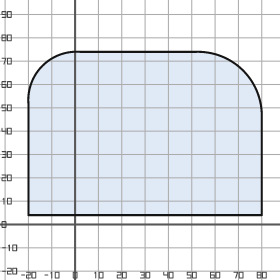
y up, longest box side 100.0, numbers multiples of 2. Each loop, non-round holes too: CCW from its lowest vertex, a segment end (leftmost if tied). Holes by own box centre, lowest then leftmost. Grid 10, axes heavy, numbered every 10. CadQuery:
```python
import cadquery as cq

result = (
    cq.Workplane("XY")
    .moveTo(-20.0, 4.0)
    .lineTo(80.0, 4.0)
    .lineTo(80.0, 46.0)
    .threePointArc((72.0, 66.0), (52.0, 74.0))
    .lineTo(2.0, 74.0)
    .threePointArc((-14.0, 68.0), (-20.0, 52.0))
    .close()
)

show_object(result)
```